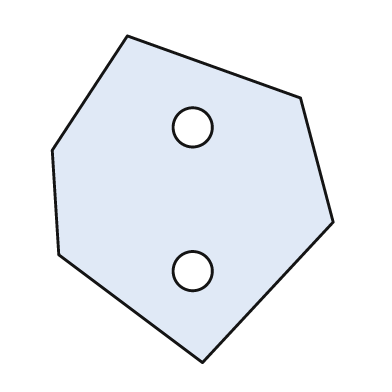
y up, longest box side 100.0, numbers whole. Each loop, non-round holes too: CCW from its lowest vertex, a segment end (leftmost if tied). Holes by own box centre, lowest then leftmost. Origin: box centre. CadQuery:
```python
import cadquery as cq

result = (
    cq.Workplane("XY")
    .moveTo(3.0, -50.0)
    .lineTo(43.0, -7.0)
    .lineTo(33.0, 31.0)
    .lineTo(-20.0, 50.0)
    .lineTo(-43.0, 15.0)
    .lineTo(-41.0, -17.0)
    .close()
    .moveTo(0.0, -22.0)
    .circle(6.0)
    .moveTo(0.0, 22.0)
    .circle(6.0)
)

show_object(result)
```